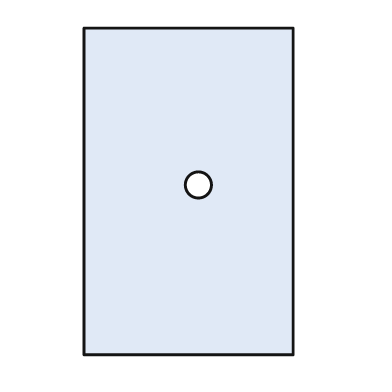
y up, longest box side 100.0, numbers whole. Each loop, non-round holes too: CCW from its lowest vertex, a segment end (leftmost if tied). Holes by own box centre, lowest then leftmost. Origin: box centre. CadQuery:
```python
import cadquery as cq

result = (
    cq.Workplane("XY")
    .moveTo(-32.0, -50.0)
    .lineTo(32.0, -50.0)
    .lineTo(32.0, 50.0)
    .lineTo(-32.0, 50.0)
    .close()
    .moveTo(3.0, 2.0)
    .circle(4.0)
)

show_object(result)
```